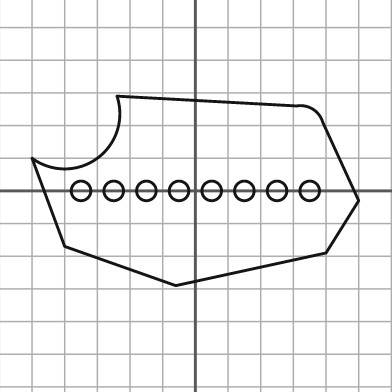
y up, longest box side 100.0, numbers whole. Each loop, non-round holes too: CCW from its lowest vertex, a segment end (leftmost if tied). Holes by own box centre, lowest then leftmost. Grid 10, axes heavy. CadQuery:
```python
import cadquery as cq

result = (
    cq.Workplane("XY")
    .moveTo(-6.0, -29.0)
    .lineTo(40.0, -19.0)
    .lineTo(50.0, -3.0)
    .lineTo(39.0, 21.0)
    .threePointArc((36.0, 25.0), (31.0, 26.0))
    .lineTo(-24.0, 29.0)
    .threePointArc((-30.0, 10.0), (-50.0, 10.0))
    .lineTo(-40.0, -17.0)
    .close()
    .moveTo(-35.0, 0.0)
    .circle(3.0)
    .moveTo(-25.0, 0.0)
    .circle(3.0)
    .moveTo(-15.0, 0.0)
    .circle(3.0)
    .moveTo(-5.0, 0.0)
    .circle(3.0)
    .moveTo(5.0, 0.0)
    .circle(3.0)
    .moveTo(15.0, 0.0)
    .circle(3.0)
    .moveTo(25.0, 0.0)
    .circle(3.0)
    .moveTo(35.0, 0.0)
    .circle(3.0)
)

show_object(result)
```